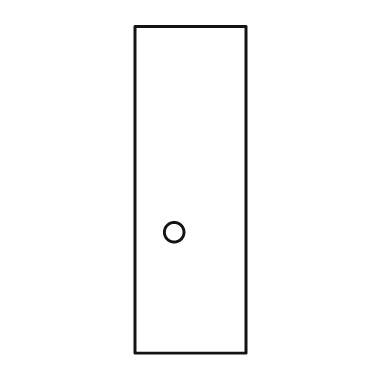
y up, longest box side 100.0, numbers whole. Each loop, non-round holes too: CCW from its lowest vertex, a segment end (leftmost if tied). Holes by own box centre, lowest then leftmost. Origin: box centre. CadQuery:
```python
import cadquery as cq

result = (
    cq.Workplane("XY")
    .moveTo(-17.0, -50.0)
    .lineTo(17.0, -50.0)
    .lineTo(17.0, 50.0)
    .lineTo(-17.0, 50.0)
    .close()
    .moveTo(-5.0, -13.0)
    .circle(3.0)
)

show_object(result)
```